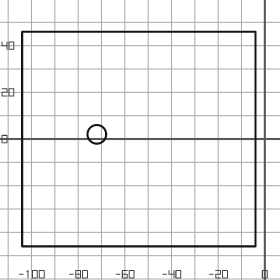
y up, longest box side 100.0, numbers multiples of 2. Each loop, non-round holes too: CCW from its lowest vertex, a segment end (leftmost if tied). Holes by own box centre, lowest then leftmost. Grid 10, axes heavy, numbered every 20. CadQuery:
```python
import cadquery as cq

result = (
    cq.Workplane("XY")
    .moveTo(-104.0, -46.0)
    .lineTo(-4.0, -46.0)
    .lineTo(-4.0, 46.0)
    .lineTo(-104.0, 46.0)
    .close()
    .moveTo(-72.0, 2.0)
    .circle(4.0)
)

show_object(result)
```